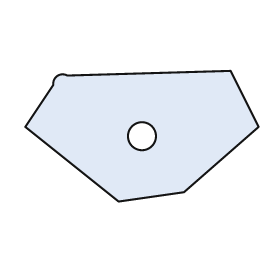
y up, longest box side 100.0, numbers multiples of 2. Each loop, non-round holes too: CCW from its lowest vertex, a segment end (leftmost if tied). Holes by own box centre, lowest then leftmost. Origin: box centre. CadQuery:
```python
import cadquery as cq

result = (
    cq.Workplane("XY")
    .moveTo(-10.0, -28.0)
    .lineTo(18.0, -24.0)
    .lineTo(50.0, 4.0)
    .lineTo(38.0, 28.0)
    .lineTo(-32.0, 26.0)
    .threePointArc((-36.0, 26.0), (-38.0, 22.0))
    .lineTo(-50.0, 4.0)
    .close()
    .moveTo(0.0, 0.0)
    .circle(6.0)
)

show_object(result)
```